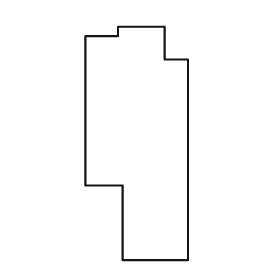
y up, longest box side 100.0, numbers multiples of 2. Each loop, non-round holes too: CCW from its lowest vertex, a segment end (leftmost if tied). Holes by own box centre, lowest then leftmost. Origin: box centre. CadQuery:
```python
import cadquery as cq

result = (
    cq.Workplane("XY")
    .moveTo(-6.0, -50.0)
    .lineTo(22.0, -50.0)
    .lineTo(22.0, 36.0)
    .lineTo(12.0, 36.0)
    .lineTo(12.0, 50.0)
    .lineTo(-8.0, 50.0)
    .lineTo(-8.0, 46.0)
    .lineTo(-22.0, 46.0)
    .lineTo(-22.0, -18.0)
    .lineTo(-6.0, -18.0)
    .close()
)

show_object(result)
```